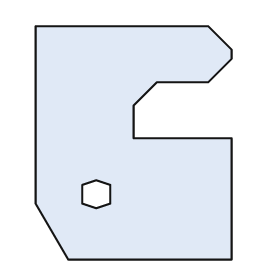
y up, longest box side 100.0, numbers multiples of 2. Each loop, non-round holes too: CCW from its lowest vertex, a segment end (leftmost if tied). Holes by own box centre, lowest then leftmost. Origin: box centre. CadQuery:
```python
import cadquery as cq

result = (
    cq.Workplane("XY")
    .moveTo(-28.0, -50.0)
    .lineTo(42.0, -50.0)
    .lineTo(42.0, 2.0)
    .lineTo(0.0, 2.0)
    .lineTo(0.0, 16.0)
    .lineTo(10.0, 26.0)
    .lineTo(32.0, 26.0)
    .lineTo(42.0, 36.0)
    .lineTo(42.0, 40.0)
    .lineTo(32.0, 50.0)
    .lineTo(-42.0, 50.0)
    .lineTo(-42.0, -26.0)
    .close()
    .moveTo(-16.0, -28.0)
    .lineTo(-10.0, -26.0)
    .lineTo(-10.0, -18.0)
    .lineTo(-16.0, -16.0)
    .lineTo(-22.0, -18.0)
    .lineTo(-22.0, -26.0)
    .close()
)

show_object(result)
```